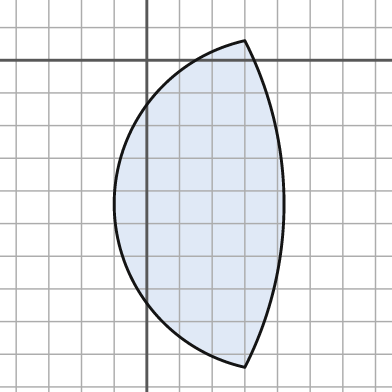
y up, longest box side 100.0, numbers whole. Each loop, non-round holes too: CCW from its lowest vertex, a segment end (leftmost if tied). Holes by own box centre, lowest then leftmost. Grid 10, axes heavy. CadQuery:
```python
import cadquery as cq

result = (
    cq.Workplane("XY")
    .moveTo(30.0, -94.0)
    .threePointArc((42.0, -44.0), (30.0, 6.0))
    .threePointArc((-10.0, -44.0), (30.0, -94.0))
    .close()
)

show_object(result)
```